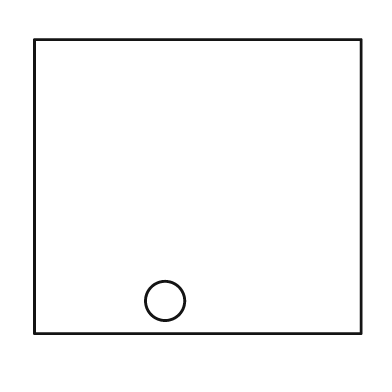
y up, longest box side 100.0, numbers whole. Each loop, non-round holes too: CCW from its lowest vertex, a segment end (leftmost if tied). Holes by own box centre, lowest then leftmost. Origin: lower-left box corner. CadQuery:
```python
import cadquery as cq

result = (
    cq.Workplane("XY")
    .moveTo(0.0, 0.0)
    .lineTo(100.0, 0.0)
    .lineTo(100.0, 90.0)
    .lineTo(0.0, 90.0)
    .close()
    .moveTo(40.0, 10.0)
    .circle(6.0)
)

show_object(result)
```